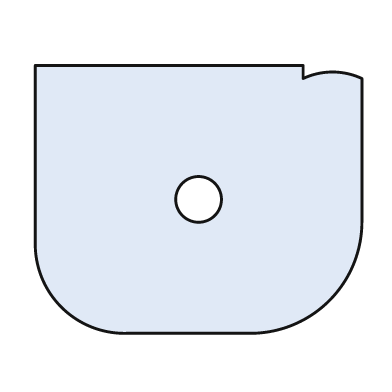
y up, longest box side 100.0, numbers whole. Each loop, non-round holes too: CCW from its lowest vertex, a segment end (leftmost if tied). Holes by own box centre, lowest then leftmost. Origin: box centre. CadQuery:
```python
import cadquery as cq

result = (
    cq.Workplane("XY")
    .moveTo(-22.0, -41.0)
    .lineTo(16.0, -41.0)
    .threePointArc((40.0, -31.0), (50.0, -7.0))
    .lineTo(50.0, 37.0)
    .threePointArc((41.0, 39.0), (32.0, 37.0))
    .lineTo(32.0, 41.0)
    .lineTo(-50.0, 41.0)
    .lineTo(-50.0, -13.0)
    .threePointArc((-42.0, -33.0), (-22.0, -41.0))
    .close()
    .moveTo(0.0, 0.0)
    .circle(7.0)
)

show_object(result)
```